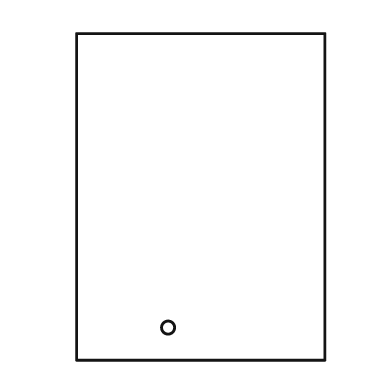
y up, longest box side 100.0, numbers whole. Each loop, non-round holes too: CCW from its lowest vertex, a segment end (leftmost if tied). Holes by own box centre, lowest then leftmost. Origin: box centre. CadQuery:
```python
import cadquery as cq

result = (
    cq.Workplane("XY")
    .moveTo(-38.0, -50.0)
    .lineTo(38.0, -50.0)
    .lineTo(38.0, 50.0)
    .lineTo(-38.0, 50.0)
    .close()
    .moveTo(-10.0, -40.0)
    .circle(2.0)
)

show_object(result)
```